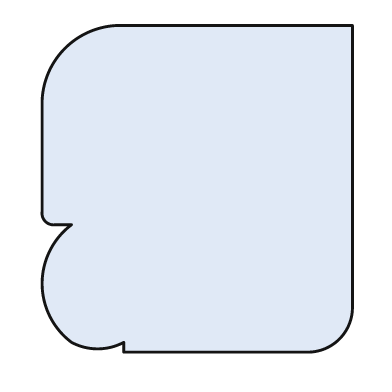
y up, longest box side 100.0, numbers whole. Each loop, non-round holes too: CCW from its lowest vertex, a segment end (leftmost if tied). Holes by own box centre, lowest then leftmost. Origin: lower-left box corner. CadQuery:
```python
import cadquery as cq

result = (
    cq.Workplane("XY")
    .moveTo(25.0, 0.0)
    .lineTo(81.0, 0.0)
    .threePointArc((91.0, 4.0), (95.0, 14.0))
    .lineTo(95.0, 100.0)
    .lineTo(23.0, 100.0)
    .threePointArc((7.0, 93.0), (0.0, 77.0))
    .lineTo(0.0, 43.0)
    .threePointArc((1.0, 40.0), (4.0, 39.0))
    .lineTo(9.0, 39.0)
    .threePointArc((0.0, 21.0), (9.0, 3.0))
    .threePointArc((17.0, 1.0), (25.0, 3.0))
    .close()
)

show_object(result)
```